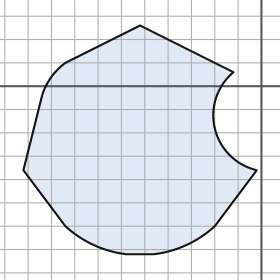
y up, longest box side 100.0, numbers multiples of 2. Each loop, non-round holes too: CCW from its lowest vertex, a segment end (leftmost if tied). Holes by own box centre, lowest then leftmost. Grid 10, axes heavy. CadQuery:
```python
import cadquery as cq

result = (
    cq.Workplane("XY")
    .moveTo(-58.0, -72.0)
    .lineTo(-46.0, -72.0)
    .threePointArc((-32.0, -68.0), (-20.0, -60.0))
    .lineTo(-2.0, -36.0)
    .threePointArc((-20.0, -18.0), (-12.0, 6.0))
    .lineTo(-52.0, 26.0)
    .lineTo(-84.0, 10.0)
    .threePointArc((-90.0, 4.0), (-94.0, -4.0))
    .lineTo(-102.0, -36.0)
    .lineTo(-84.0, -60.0)
    .threePointArc((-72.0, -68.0), (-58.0, -72.0))
    .close()
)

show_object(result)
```